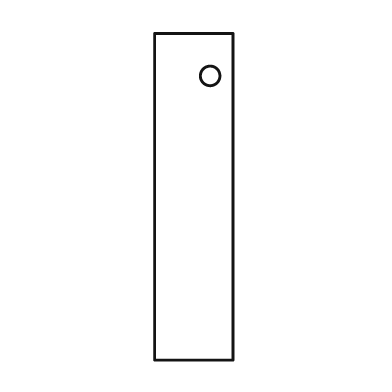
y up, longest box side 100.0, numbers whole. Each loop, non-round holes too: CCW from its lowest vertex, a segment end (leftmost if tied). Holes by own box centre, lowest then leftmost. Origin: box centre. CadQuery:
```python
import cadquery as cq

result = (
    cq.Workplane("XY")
    .moveTo(-12.0, -50.0)
    .lineTo(12.0, -50.0)
    .lineTo(12.0, 50.0)
    .lineTo(-12.0, 50.0)
    .close()
    .moveTo(5.0, 37.0)
    .circle(3.0)
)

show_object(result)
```